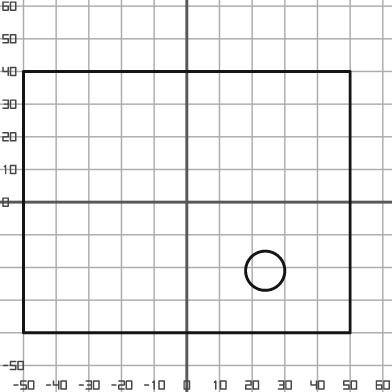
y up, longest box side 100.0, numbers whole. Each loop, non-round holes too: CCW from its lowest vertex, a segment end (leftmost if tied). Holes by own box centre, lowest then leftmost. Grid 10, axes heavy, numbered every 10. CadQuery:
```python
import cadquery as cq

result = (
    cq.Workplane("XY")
    .moveTo(-50.0, -40.0)
    .lineTo(50.0, -40.0)
    .lineTo(50.0, 40.0)
    .lineTo(-50.0, 40.0)
    .close()
    .moveTo(24.0, -21.0)
    .circle(6.0)
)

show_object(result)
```